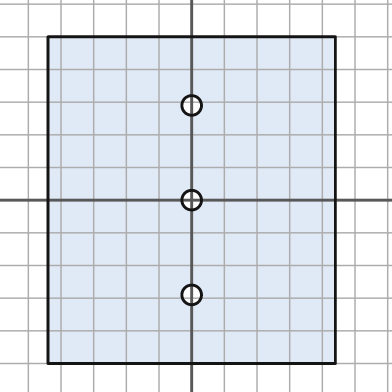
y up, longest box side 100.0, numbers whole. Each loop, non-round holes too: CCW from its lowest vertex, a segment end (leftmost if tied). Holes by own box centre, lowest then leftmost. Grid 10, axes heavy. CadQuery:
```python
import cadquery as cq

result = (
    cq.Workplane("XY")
    .moveTo(-44.0, -50.0)
    .lineTo(44.0, -50.0)
    .lineTo(44.0, 50.0)
    .lineTo(-44.0, 50.0)
    .close()
    .moveTo(0.0, -29.0)
    .circle(3.0)
    .moveTo(0.0, 0.0)
    .circle(3.0)
    .moveTo(0.0, 29.0)
    .circle(3.0)
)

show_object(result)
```